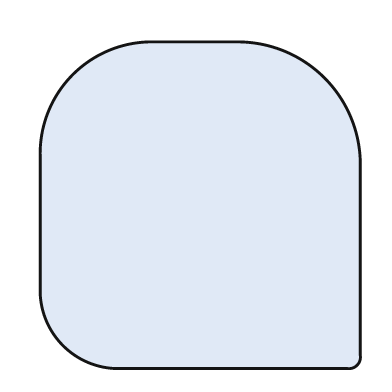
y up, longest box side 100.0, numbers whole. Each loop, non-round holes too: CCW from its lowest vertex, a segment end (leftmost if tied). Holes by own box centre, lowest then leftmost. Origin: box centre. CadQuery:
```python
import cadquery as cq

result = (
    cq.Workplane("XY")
    .moveTo(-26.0, -50.0)
    .lineTo(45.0, -50.0)
    .threePointArc((48.0, -49.0), (49.0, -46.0))
    .lineTo(49.0, 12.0)
    .threePointArc((38.0, 39.0), (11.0, 50.0))
    .lineTo(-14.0, 50.0)
    .threePointArc((-39.0, 40.0), (-49.0, 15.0))
    .lineTo(-49.0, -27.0)
    .threePointArc((-42.0, -43.0), (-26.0, -50.0))
    .close()
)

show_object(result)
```